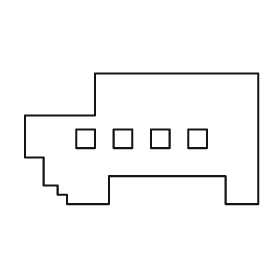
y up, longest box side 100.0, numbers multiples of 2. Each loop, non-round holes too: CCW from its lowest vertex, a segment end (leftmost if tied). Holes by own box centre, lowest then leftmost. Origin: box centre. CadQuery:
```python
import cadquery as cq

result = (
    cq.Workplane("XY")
    .moveTo(-32.0, -28.0)
    .lineTo(-14.0, -28.0)
    .lineTo(-14.0, -16.0)
    .lineTo(36.0, -16.0)
    .lineTo(36.0, -28.0)
    .lineTo(50.0, -28.0)
    .lineTo(50.0, 28.0)
    .lineTo(-20.0, 28.0)
    .lineTo(-20.0, 10.0)
    .lineTo(-50.0, 10.0)
    .lineTo(-50.0, -8.0)
    .lineTo(-42.0, -8.0)
    .lineTo(-42.0, -20.0)
    .lineTo(-36.0, -20.0)
    .lineTo(-36.0, -24.0)
    .lineTo(-32.0, -24.0)
    .close()
    .moveTo(-28.0, -4.0)
    .lineTo(-20.0, -4.0)
    .lineTo(-20.0, 4.0)
    .lineTo(-28.0, 4.0)
    .close()
    .moveTo(-12.0, -4.0)
    .lineTo(-4.0, -4.0)
    .lineTo(-4.0, 4.0)
    .lineTo(-12.0, 4.0)
    .close()
    .moveTo(4.0, -4.0)
    .lineTo(12.0, -4.0)
    .lineTo(12.0, 4.0)
    .lineTo(4.0, 4.0)
    .close()
    .moveTo(20.0, -4.0)
    .lineTo(28.0, -4.0)
    .lineTo(28.0, 4.0)
    .lineTo(20.0, 4.0)
    .close()
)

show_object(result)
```